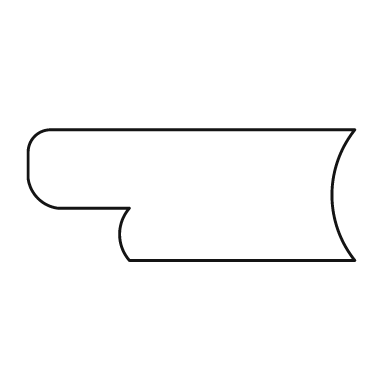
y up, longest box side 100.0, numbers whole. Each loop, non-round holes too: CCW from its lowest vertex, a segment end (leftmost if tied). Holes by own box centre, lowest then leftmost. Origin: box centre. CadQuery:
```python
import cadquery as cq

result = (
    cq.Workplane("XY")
    .moveTo(-19.0, -20.0)
    .lineTo(50.0, -20.0)
    .threePointArc((43.0, 0.0), (50.0, 20.0))
    .lineTo(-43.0, 20.0)
    .threePointArc((-48.0, 18.0), (-50.0, 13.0))
    .lineTo(-50.0, 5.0)
    .threePointArc((-47.0, -1.0), (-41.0, -4.0))
    .lineTo(-19.0, -4.0)
    .threePointArc((-22.0, -12.0), (-19.0, -20.0))
    .close()
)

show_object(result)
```